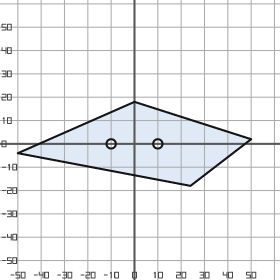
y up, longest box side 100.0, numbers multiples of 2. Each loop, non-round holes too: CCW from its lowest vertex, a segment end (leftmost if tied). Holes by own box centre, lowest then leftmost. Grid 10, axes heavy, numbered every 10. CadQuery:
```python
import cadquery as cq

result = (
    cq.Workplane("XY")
    .moveTo(24.0, -18.0)
    .lineTo(50.0, 2.0)
    .lineTo(0.0, 18.0)
    .lineTo(-50.0, -4.0)
    .close()
    .moveTo(-10.0, 0.0)
    .circle(2.0)
    .moveTo(10.0, 0.0)
    .circle(2.0)
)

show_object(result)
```